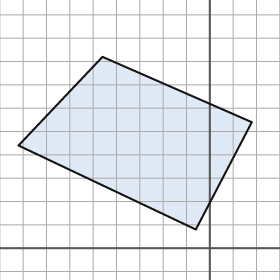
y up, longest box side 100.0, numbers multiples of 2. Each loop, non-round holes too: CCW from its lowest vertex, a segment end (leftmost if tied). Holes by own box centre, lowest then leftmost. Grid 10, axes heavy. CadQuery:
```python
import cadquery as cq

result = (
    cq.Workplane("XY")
    .moveTo(-6.0, 8.0)
    .lineTo(18.0, 54.0)
    .lineTo(-46.0, 82.0)
    .lineTo(-82.0, 44.0)
    .close()
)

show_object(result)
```